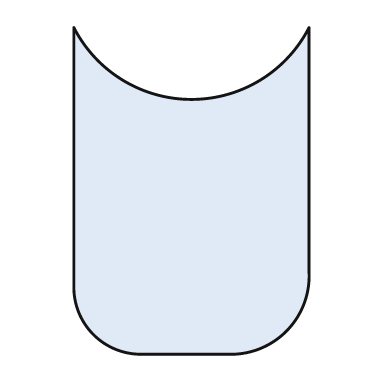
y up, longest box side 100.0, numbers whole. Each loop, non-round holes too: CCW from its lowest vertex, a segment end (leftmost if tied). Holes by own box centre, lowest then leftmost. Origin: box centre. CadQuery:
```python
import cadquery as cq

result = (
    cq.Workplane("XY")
    .moveTo(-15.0, -50.0)
    .lineTo(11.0, -50.0)
    .threePointArc((29.0, -43.0), (36.0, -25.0))
    .lineTo(36.0, 50.0)
    .threePointArc((0.0, 28.0), (-36.0, 50.0))
    .lineTo(-36.0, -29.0)
    .threePointArc((-30.0, -44.0), (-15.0, -50.0))
    .close()
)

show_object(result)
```